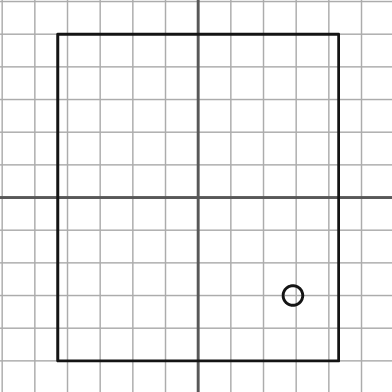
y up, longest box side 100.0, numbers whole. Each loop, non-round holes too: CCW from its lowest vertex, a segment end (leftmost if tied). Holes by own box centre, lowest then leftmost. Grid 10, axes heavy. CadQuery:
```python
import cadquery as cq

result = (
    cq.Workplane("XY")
    .moveTo(-43.0, -50.0)
    .lineTo(43.0, -50.0)
    .lineTo(43.0, 50.0)
    .lineTo(-43.0, 50.0)
    .close()
    .moveTo(29.0, -30.0)
    .circle(3.0)
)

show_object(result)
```